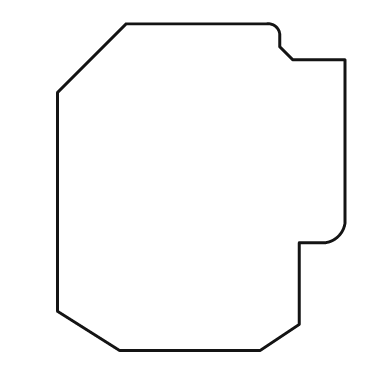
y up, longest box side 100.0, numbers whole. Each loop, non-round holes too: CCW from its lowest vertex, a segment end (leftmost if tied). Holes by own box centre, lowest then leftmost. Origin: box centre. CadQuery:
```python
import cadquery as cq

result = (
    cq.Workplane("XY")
    .moveTo(-25.0, -50.0)
    .lineTo(18.0, -50.0)
    .lineTo(30.0, -42.0)
    .lineTo(30.0, -17.0)
    .lineTo(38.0, -17.0)
    .threePointArc((42.0, -15.0), (44.0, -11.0))
    .lineTo(44.0, 39.0)
    .lineTo(28.0, 39.0)
    .lineTo(24.0, 43.0)
    .lineTo(24.0, 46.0)
    .threePointArc((23.0, 49.0), (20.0, 50.0))
    .lineTo(-23.0, 50.0)
    .lineTo(-44.0, 29.0)
    .lineTo(-44.0, -38.0)
    .close()
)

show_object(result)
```